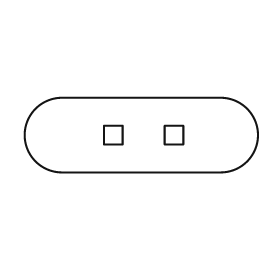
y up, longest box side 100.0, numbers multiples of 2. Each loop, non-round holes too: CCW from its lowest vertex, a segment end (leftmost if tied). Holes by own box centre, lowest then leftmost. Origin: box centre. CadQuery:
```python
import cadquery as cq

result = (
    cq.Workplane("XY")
    .moveTo(-34.0, -16.0)
    .lineTo(34.0, -16.0)
    .threePointArc((50.0, 0.0), (34.0, 16.0))
    .lineTo(-34.0, 16.0)
    .threePointArc((-50.0, 0.0), (-34.0, -16.0))
    .close()
    .moveTo(-16.0, -4.0)
    .lineTo(-8.0, -4.0)
    .lineTo(-8.0, 4.0)
    .lineTo(-16.0, 4.0)
    .close()
    .moveTo(10.0, -4.0)
    .lineTo(18.0, -4.0)
    .lineTo(18.0, 4.0)
    .lineTo(10.0, 4.0)
    .close()
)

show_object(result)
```